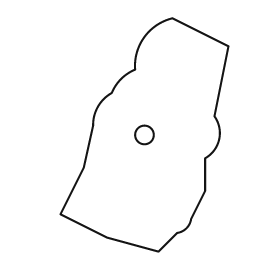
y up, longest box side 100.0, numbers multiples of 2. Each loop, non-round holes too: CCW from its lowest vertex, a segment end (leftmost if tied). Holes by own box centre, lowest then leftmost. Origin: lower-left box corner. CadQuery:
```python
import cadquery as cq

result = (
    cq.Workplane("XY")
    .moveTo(42.0, 0.0)
    .lineTo(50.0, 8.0)
    .threePointArc((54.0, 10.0), (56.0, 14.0))
    .lineTo(62.0, 26.0)
    .lineTo(62.0, 40.0)
    .threePointArc((68.0, 48.0), (66.0, 58.0))
    .lineTo(72.0, 88.0)
    .lineTo(48.0, 100.0)
    .threePointArc((36.0, 92.0), (32.0, 78.0))
    .threePointArc((26.0, 74.0), (22.0, 68.0))
    .threePointArc((16.0, 62.0), (14.0, 54.0))
    .lineTo(10.0, 36.0)
    .lineTo(0.0, 16.0)
    .lineTo(20.0, 6.0)
    .close()
    .moveTo(36.0, 50.0)
    .circle(4.0)
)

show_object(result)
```